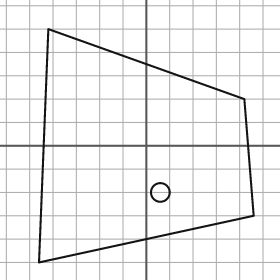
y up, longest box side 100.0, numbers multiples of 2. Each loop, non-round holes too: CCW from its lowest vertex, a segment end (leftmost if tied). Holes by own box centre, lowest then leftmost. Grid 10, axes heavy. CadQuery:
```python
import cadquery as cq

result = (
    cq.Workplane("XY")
    .moveTo(-46.0, -50.0)
    .lineTo(46.0, -30.0)
    .lineTo(42.0, 20.0)
    .lineTo(-42.0, 50.0)
    .close()
    .moveTo(6.0, -20.0)
    .circle(4.0)
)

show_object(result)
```